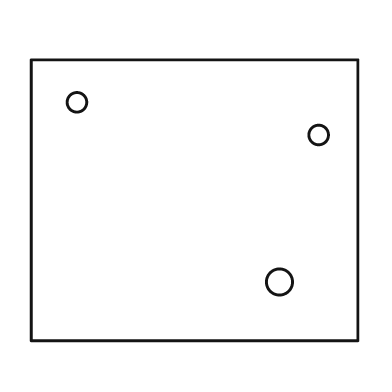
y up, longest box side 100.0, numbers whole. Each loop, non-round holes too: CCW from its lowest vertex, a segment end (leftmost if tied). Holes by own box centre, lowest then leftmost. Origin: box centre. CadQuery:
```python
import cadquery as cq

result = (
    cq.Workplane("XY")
    .moveTo(-50.0, -43.0)
    .lineTo(50.0, -43.0)
    .lineTo(50.0, 43.0)
    .lineTo(-50.0, 43.0)
    .close()
    .moveTo(26.0, -25.0)
    .circle(4.0)
    .moveTo(38.0, 20.0)
    .circle(3.0)
    .moveTo(-36.0, 30.0)
    .circle(3.0)
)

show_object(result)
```